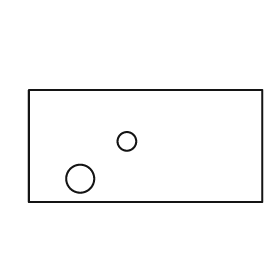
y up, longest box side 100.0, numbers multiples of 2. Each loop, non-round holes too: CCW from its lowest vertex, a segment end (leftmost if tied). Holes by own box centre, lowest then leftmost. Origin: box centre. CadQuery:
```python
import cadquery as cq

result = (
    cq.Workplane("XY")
    .moveTo(-50.0, -24.0)
    .lineTo(50.0, -24.0)
    .lineTo(50.0, 24.0)
    .lineTo(-50.0, 24.0)
    .close()
    .moveTo(-28.0, -14.0)
    .circle(6.0)
    .moveTo(-8.0, 2.0)
    .circle(4.0)
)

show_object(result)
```